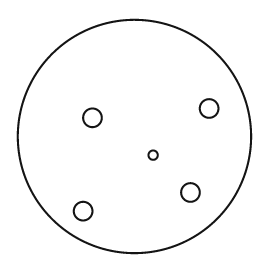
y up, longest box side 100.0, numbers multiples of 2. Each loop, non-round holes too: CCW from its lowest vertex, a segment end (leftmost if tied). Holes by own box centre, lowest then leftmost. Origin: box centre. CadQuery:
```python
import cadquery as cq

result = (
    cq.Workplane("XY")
    .moveTo(0.0, 0.0)
    .circle(50.0)
    .moveTo(-22.0, -32.0)
    .circle(4.0)
    .moveTo(24.0, -24.0)
    .circle(4.0)
    .moveTo(8.0, -8.0)
    .circle(2.0)
    .moveTo(-18.0, 8.0)
    .circle(4.0)
    .moveTo(32.0, 12.0)
    .circle(4.0)
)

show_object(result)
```